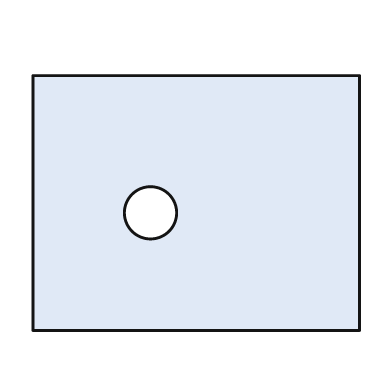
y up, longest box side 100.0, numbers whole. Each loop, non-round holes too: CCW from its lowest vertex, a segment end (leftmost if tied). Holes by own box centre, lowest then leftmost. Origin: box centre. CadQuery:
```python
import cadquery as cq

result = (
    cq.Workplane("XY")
    .moveTo(-50.0, -39.0)
    .lineTo(50.0, -39.0)
    .lineTo(50.0, 39.0)
    .lineTo(-50.0, 39.0)
    .close()
    .moveTo(-14.0, -3.0)
    .circle(8.0)
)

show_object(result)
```